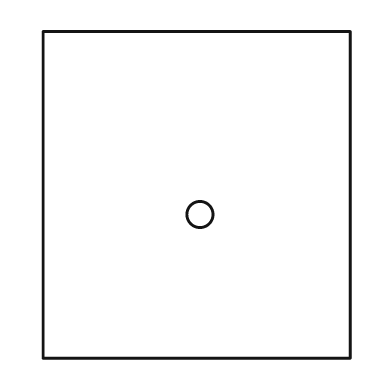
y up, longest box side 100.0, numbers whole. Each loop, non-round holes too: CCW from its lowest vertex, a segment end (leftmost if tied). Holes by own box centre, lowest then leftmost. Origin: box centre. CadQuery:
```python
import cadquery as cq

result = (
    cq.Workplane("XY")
    .moveTo(-47.0, -50.0)
    .lineTo(47.0, -50.0)
    .lineTo(47.0, 50.0)
    .lineTo(-47.0, 50.0)
    .close()
    .moveTo(1.0, -6.0)
    .circle(4.0)
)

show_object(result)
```